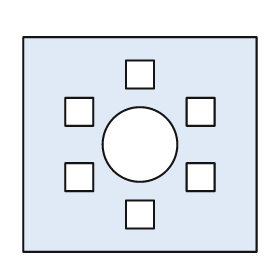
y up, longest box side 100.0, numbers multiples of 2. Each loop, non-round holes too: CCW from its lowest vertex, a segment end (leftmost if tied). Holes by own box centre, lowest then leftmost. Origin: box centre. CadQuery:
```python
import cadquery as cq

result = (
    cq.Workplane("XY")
    .moveTo(-50.0, -46.0)
    .lineTo(50.0, -46.0)
    .lineTo(50.0, 46.0)
    .lineTo(-50.0, 46.0)
    .close()
    .moveTo(-6.0, -36.0)
    .lineTo(6.0, -36.0)
    .lineTo(6.0, -24.0)
    .lineTo(-6.0, -24.0)
    .close()
    .moveTo(-32.0, -20.0)
    .lineTo(-20.0, -20.0)
    .lineTo(-20.0, -8.0)
    .lineTo(-32.0, -8.0)
    .close()
    .moveTo(20.0, -20.0)
    .lineTo(32.0, -20.0)
    .lineTo(32.0, -8.0)
    .lineTo(20.0, -8.0)
    .close()
    .moveTo(0.0, 0.0)
    .circle(16.0)
    .moveTo(-32.0, 8.0)
    .lineTo(-20.0, 8.0)
    .lineTo(-20.0, 20.0)
    .lineTo(-32.0, 20.0)
    .close()
    .moveTo(20.0, 8.0)
    .lineTo(32.0, 8.0)
    .lineTo(32.0, 20.0)
    .lineTo(20.0, 20.0)
    .close()
    .moveTo(-6.0, 24.0)
    .lineTo(6.0, 24.0)
    .lineTo(6.0, 36.0)
    .lineTo(-6.0, 36.0)
    .close()
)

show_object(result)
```